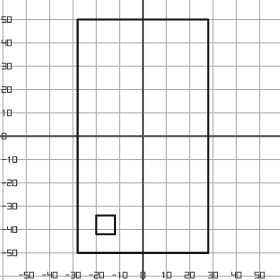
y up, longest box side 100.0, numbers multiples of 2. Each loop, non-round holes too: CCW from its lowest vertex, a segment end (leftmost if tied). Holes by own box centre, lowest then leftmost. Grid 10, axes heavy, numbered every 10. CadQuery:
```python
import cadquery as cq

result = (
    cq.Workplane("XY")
    .moveTo(-28.0, -50.0)
    .lineTo(28.0, -50.0)
    .lineTo(28.0, 50.0)
    .lineTo(-28.0, 50.0)
    .close()
    .moveTo(-20.0, -42.0)
    .lineTo(-12.0, -42.0)
    .lineTo(-12.0, -34.0)
    .lineTo(-20.0, -34.0)
    .close()
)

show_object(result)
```